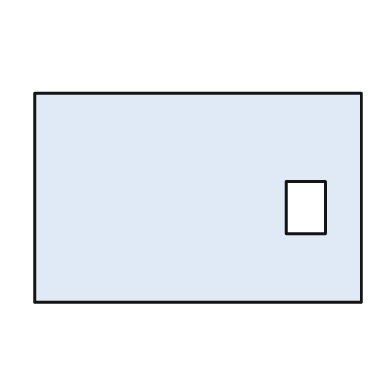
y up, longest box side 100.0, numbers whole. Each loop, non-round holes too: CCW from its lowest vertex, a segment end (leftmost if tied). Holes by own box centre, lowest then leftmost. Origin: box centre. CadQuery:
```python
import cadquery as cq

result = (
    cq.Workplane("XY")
    .moveTo(-50.0, -32.0)
    .lineTo(50.0, -32.0)
    .lineTo(50.0, 32.0)
    .lineTo(-50.0, 32.0)
    .close()
    .moveTo(27.0, -11.0)
    .lineTo(39.0, -11.0)
    .lineTo(39.0, 5.0)
    .lineTo(27.0, 5.0)
    .close()
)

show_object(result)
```